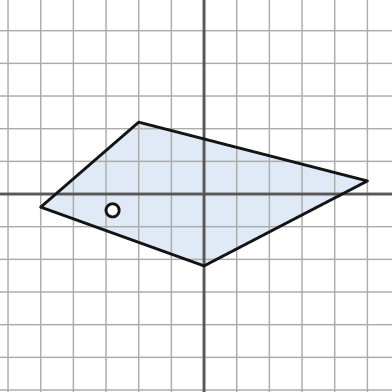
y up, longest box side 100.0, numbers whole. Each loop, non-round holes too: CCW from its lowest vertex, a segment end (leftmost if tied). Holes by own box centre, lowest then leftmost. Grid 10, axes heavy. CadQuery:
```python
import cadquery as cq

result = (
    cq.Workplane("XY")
    .moveTo(0.0, -22.0)
    .lineTo(50.0, 4.0)
    .lineTo(-20.0, 22.0)
    .lineTo(-50.0, -4.0)
    .close()
    .moveTo(-28.0, -5.0)
    .circle(2.0)
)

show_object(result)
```